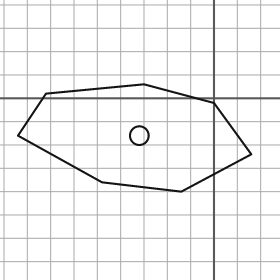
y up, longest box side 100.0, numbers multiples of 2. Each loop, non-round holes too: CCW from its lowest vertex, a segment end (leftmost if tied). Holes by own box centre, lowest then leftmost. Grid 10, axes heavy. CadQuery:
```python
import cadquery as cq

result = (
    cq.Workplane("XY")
    .moveTo(-14.0, -40.0)
    .lineTo(16.0, -24.0)
    .lineTo(0.0, -2.0)
    .lineTo(-30.0, 6.0)
    .lineTo(-72.0, 2.0)
    .lineTo(-84.0, -16.0)
    .lineTo(-48.0, -36.0)
    .close()
    .moveTo(-32.0, -16.0)
    .circle(4.0)
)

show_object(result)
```